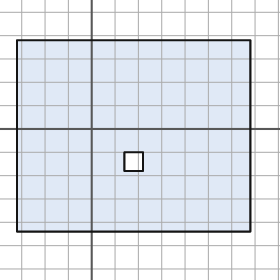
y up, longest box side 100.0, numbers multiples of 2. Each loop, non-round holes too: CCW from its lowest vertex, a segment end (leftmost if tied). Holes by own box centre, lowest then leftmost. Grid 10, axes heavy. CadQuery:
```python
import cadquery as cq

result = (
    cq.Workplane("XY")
    .moveTo(-32.0, -44.0)
    .lineTo(68.0, -44.0)
    .lineTo(68.0, 38.0)
    .lineTo(-32.0, 38.0)
    .close()
    .moveTo(14.0, -18.0)
    .lineTo(22.0, -18.0)
    .lineTo(22.0, -10.0)
    .lineTo(14.0, -10.0)
    .close()
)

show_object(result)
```